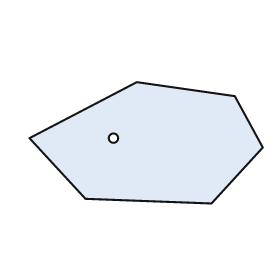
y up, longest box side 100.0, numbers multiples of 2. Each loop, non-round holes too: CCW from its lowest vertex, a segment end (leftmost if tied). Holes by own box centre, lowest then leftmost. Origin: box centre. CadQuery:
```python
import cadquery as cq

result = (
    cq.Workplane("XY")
    .moveTo(28.0, -26.0)
    .lineTo(50.0, -2.0)
    .lineTo(38.0, 20.0)
    .lineTo(-4.0, 26.0)
    .lineTo(-50.0, 2.0)
    .lineTo(-26.0, -24.0)
    .close()
    .moveTo(-14.0, 2.0)
    .circle(2.0)
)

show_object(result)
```